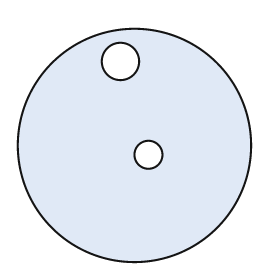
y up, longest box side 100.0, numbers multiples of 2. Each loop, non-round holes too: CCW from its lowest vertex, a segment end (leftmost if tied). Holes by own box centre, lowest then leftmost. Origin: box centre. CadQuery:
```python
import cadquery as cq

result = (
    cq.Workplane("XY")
    .moveTo(0.0, 0.0)
    .circle(50.0)
    .moveTo(6.0, -4.0)
    .circle(6.0)
    .moveTo(-6.0, 36.0)
    .circle(8.0)
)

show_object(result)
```